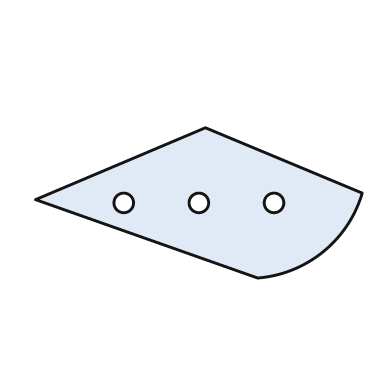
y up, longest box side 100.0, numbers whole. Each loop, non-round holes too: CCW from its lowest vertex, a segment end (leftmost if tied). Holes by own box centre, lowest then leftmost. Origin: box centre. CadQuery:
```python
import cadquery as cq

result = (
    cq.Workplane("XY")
    .moveTo(18.0, -23.0)
    .threePointArc((38.0, -15.0), (50.0, 3.0))
    .lineTo(2.0, 23.0)
    .lineTo(-50.0, 1.0)
    .close()
    .moveTo(-23.0, 0.0)
    .circle(3.0)
    .moveTo(0.0, 0.0)
    .circle(3.0)
    .moveTo(23.0, 0.0)
    .circle(3.0)
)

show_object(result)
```